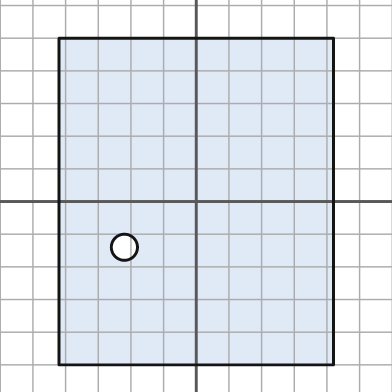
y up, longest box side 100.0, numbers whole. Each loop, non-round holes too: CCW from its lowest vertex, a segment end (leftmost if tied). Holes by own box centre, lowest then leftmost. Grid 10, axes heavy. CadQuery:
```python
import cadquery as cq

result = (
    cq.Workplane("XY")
    .moveTo(-42.0, -50.0)
    .lineTo(42.0, -50.0)
    .lineTo(42.0, 50.0)
    .lineTo(-42.0, 50.0)
    .close()
    .moveTo(-22.0, -14.0)
    .circle(4.0)
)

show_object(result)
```